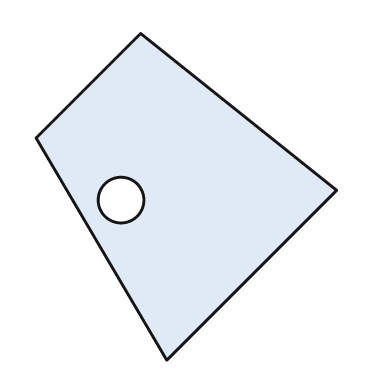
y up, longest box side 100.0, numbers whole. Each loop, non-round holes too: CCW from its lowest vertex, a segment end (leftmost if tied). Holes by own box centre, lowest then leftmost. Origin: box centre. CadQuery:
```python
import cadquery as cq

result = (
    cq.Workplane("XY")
    .moveTo(-6.0, -50.0)
    .lineTo(46.0, 2.0)
    .lineTo(-14.0, 50.0)
    .lineTo(-46.0, 18.0)
    .close()
    .moveTo(-20.0, -1.0)
    .circle(7.0)
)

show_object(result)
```